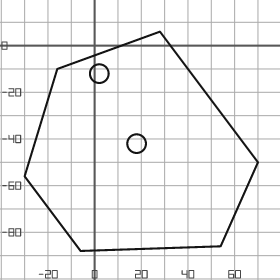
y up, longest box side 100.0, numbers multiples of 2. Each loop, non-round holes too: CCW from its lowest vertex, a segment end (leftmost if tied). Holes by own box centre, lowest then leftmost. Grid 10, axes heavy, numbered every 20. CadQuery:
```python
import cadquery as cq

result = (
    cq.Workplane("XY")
    .moveTo(-6.0, -88.0)
    .lineTo(54.0, -86.0)
    .lineTo(70.0, -50.0)
    .lineTo(28.0, 6.0)
    .lineTo(-16.0, -10.0)
    .lineTo(-30.0, -56.0)
    .close()
    .moveTo(18.0, -42.0)
    .circle(4.0)
    .moveTo(2.0, -12.0)
    .circle(4.0)
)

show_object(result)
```